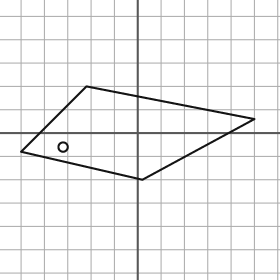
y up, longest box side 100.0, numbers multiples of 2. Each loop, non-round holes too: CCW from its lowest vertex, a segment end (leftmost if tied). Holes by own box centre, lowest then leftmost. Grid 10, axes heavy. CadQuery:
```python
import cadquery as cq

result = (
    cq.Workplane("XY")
    .moveTo(2.0, -20.0)
    .lineTo(50.0, 6.0)
    .lineTo(-22.0, 20.0)
    .lineTo(-50.0, -8.0)
    .close()
    .moveTo(-32.0, -6.0)
    .circle(2.0)
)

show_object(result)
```